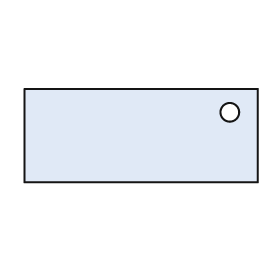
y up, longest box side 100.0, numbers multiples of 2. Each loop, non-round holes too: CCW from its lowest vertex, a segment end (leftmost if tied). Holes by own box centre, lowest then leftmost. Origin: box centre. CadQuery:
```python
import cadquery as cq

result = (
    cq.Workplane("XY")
    .moveTo(-50.0, -20.0)
    .lineTo(50.0, -20.0)
    .lineTo(50.0, 20.0)
    .lineTo(-50.0, 20.0)
    .close()
    .moveTo(38.0, 10.0)
    .circle(4.0)
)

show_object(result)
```